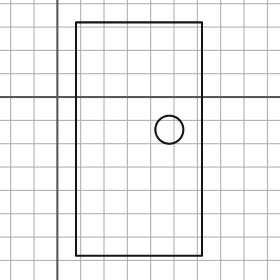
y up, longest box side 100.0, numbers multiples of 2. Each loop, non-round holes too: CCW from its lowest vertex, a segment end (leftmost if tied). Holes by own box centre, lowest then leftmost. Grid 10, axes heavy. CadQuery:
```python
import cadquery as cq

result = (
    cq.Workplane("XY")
    .moveTo(8.0, -68.0)
    .lineTo(62.0, -68.0)
    .lineTo(62.0, 32.0)
    .lineTo(8.0, 32.0)
    .close()
    .moveTo(48.0, -14.0)
    .circle(6.0)
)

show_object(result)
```